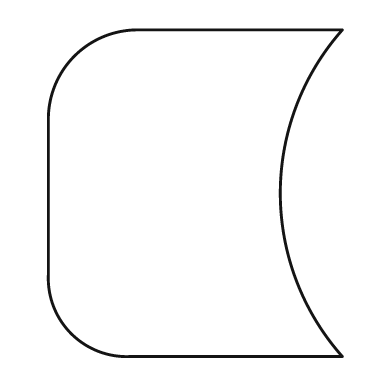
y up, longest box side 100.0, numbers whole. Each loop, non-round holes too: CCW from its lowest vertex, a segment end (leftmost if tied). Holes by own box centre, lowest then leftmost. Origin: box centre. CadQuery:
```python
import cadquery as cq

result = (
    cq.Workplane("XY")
    .moveTo(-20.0, -50.0)
    .lineTo(45.0, -50.0)
    .threePointArc((26.0, 0.0), (45.0, 50.0))
    .lineTo(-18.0, 50.0)
    .threePointArc((-37.0, 42.0), (-45.0, 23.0))
    .lineTo(-45.0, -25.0)
    .threePointArc((-38.0, -43.0), (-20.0, -50.0))
    .close()
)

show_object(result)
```